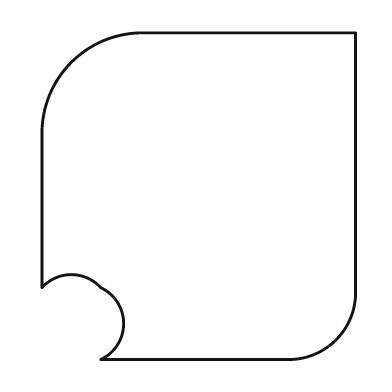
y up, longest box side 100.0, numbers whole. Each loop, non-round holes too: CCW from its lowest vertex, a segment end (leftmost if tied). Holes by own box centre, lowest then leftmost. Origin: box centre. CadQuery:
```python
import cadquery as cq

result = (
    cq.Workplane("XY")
    .moveTo(-30.0, -50.0)
    .lineTo(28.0, -50.0)
    .threePointArc((42.0, -44.0), (48.0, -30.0))
    .lineTo(48.0, 50.0)
    .lineTo(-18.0, 50.0)
    .threePointArc((-39.0, 41.0), (-48.0, 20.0))
    .lineTo(-48.0, -28.0)
    .threePointArc((-39.0, -24.0), (-30.0, -28.0))
    .threePointArc((-23.0, -39.0), (-30.0, -50.0))
    .close()
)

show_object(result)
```